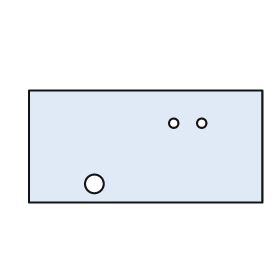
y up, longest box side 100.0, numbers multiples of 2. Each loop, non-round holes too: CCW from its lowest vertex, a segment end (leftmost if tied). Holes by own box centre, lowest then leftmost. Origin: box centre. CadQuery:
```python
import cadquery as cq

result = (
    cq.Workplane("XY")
    .moveTo(-50.0, -24.0)
    .lineTo(50.0, -24.0)
    .lineTo(50.0, 24.0)
    .lineTo(-50.0, 24.0)
    .close()
    .moveTo(-22.0, -16.0)
    .circle(4.0)
    .moveTo(12.0, 10.0)
    .circle(2.0)
    .moveTo(24.0, 10.0)
    .circle(2.0)
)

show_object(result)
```